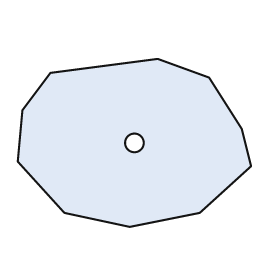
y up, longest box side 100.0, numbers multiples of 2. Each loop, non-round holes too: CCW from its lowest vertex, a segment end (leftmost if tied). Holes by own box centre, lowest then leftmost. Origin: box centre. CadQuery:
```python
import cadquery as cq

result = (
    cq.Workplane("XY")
    .moveTo(-2.0, -36.0)
    .lineTo(28.0, -30.0)
    .lineTo(50.0, -10.0)
    .lineTo(46.0, 6.0)
    .lineTo(32.0, 28.0)
    .lineTo(10.0, 36.0)
    .lineTo(-36.0, 30.0)
    .lineTo(-48.0, 14.0)
    .lineTo(-50.0, -8.0)
    .lineTo(-30.0, -30.0)
    .close()
    .moveTo(0.0, 0.0)
    .circle(4.0)
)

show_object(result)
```